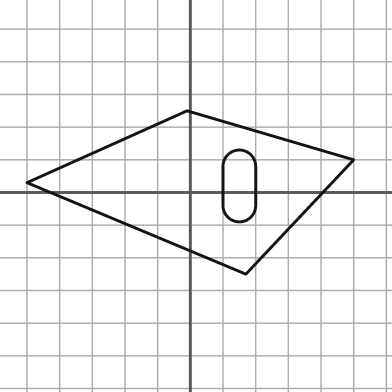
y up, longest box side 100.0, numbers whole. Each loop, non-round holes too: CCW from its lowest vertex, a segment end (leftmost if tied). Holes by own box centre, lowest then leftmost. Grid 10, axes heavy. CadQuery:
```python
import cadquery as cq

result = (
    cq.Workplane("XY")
    .moveTo(17.0, -25.0)
    .lineTo(50.0, 10.0)
    .lineTo(-1.0, 25.0)
    .lineTo(-50.0, 3.0)
    .close()
    .moveTo(10.0, -4.0)
    .threePointArc((15.0, -9.0), (20.0, -4.0))
    .lineTo(20.0, 8.0)
    .threePointArc((15.0, 13.0), (10.0, 8.0))
    .close()
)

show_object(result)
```